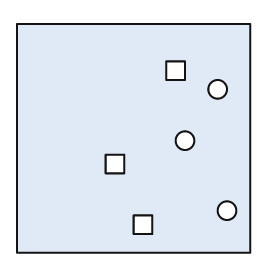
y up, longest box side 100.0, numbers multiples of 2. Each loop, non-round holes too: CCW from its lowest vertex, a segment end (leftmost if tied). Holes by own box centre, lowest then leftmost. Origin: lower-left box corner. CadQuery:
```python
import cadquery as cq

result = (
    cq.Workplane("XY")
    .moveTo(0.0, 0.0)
    .lineTo(100.0, 0.0)
    .lineTo(100.0, 98.0)
    .lineTo(0.0, 98.0)
    .close()
    .moveTo(50.0, 8.0)
    .lineTo(58.0, 8.0)
    .lineTo(58.0, 16.0)
    .lineTo(50.0, 16.0)
    .close()
    .moveTo(90.0, 18.0)
    .circle(4.0)
    .moveTo(38.0, 34.0)
    .lineTo(46.0, 34.0)
    .lineTo(46.0, 42.0)
    .lineTo(38.0, 42.0)
    .close()
    .moveTo(72.0, 48.0)
    .circle(4.0)
    .moveTo(86.0, 70.0)
    .circle(4.0)
    .moveTo(64.0, 74.0)
    .lineTo(72.0, 74.0)
    .lineTo(72.0, 82.0)
    .lineTo(64.0, 82.0)
    .close()
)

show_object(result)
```